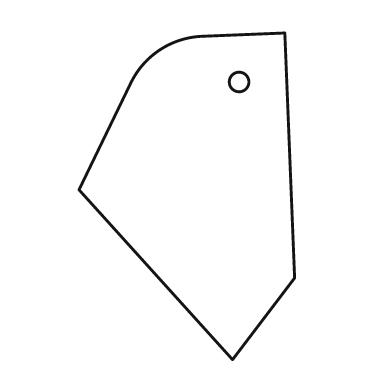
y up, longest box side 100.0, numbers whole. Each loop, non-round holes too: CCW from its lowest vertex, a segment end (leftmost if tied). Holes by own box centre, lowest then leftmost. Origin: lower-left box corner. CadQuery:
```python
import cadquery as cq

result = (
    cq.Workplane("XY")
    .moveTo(47.0, 0.0)
    .lineTo(66.0, 25.0)
    .lineTo(63.0, 100.0)
    .lineTo(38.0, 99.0)
    .threePointArc((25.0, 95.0), (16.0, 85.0))
    .lineTo(0.0, 52.0)
    .close()
    .moveTo(49.0, 85.0)
    .circle(3.0)
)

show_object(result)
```